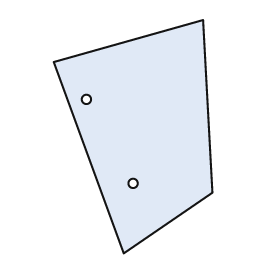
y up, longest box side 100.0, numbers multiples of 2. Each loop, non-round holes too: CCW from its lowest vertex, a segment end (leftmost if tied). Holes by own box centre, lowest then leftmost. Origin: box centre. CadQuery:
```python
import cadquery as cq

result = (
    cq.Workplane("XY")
    .moveTo(-4.0, -50.0)
    .lineTo(34.0, -24.0)
    .lineTo(30.0, 50.0)
    .lineTo(-34.0, 32.0)
    .close()
    .moveTo(0.0, -20.0)
    .circle(2.0)
    .moveTo(-20.0, 16.0)
    .circle(2.0)
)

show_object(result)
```